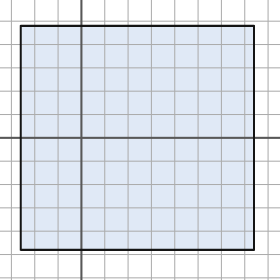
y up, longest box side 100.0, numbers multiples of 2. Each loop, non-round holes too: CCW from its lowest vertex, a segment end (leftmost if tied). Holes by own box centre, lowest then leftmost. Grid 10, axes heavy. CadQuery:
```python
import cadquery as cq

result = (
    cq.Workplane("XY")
    .moveTo(-26.0, -48.0)
    .lineTo(74.0, -48.0)
    .lineTo(74.0, 48.0)
    .lineTo(-26.0, 48.0)
    .close()
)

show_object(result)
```